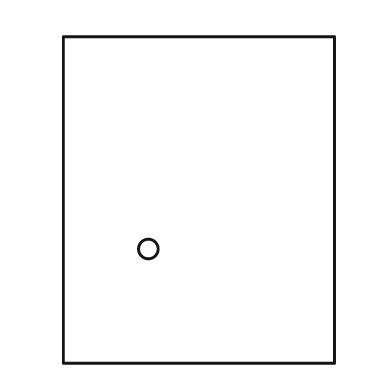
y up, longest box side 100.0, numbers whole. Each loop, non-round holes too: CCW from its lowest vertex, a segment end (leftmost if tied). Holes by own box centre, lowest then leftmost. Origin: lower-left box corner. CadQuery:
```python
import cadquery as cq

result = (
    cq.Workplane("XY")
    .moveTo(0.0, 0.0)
    .lineTo(83.0, 0.0)
    .lineTo(83.0, 100.0)
    .lineTo(0.0, 100.0)
    .close()
    .moveTo(26.0, 35.0)
    .circle(3.0)
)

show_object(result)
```